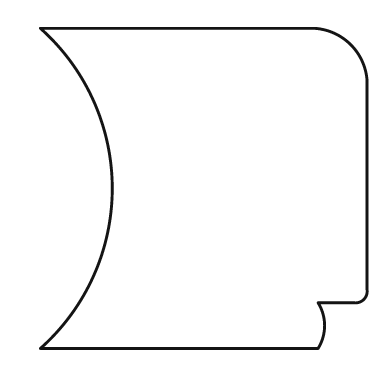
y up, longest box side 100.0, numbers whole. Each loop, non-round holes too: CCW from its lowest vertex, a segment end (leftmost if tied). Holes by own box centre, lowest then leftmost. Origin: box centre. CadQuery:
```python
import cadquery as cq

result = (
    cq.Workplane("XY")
    .moveTo(-50.0, -49.0)
    .lineTo(35.0, -49.0)
    .threePointArc((37.0, -42.0), (35.0, -35.0))
    .lineTo(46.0, -35.0)
    .threePointArc((49.0, -34.0), (50.0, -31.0))
    .lineTo(50.0, 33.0)
    .threePointArc((45.0, 44.0), (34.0, 49.0))
    .lineTo(-50.0, 49.0)
    .threePointArc((-28.0, 0.0), (-50.0, -49.0))
    .close()
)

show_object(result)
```